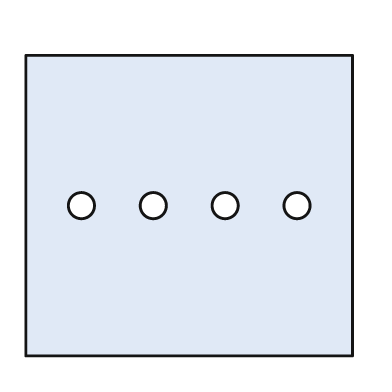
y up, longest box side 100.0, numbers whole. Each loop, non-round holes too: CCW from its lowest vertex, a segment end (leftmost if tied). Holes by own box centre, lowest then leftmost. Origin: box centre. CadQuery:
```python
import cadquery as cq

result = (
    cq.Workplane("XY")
    .moveTo(-50.0, -46.0)
    .lineTo(50.0, -46.0)
    .lineTo(50.0, 46.0)
    .lineTo(-50.0, 46.0)
    .close()
    .moveTo(-33.0, 0.0)
    .circle(4.0)
    .moveTo(-11.0, 0.0)
    .circle(4.0)
    .moveTo(11.0, 0.0)
    .circle(4.0)
    .moveTo(33.0, 0.0)
    .circle(4.0)
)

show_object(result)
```